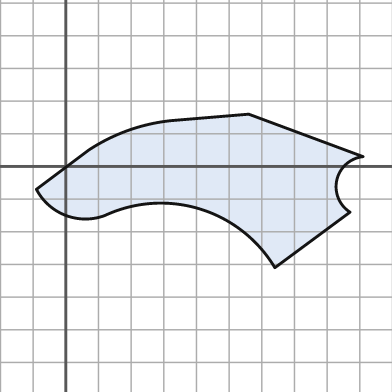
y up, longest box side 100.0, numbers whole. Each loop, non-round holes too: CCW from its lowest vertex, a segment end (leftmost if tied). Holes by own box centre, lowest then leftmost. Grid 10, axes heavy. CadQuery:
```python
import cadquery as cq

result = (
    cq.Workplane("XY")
    .moveTo(64.0, -31.0)
    .lineTo(87.0, -14.0)
    .threePointArc((83.0, -4.0), (91.0, 3.0))
    .lineTo(56.0, 16.0)
    .lineTo(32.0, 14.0)
    .threePointArc((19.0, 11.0), (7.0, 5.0))
    .lineTo(-9.0, -7.0)
    .threePointArc((0.0, -15.0), (12.0, -15.0))
    .threePointArc((41.0, -13.0), (64.0, -31.0))
    .close()
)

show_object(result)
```